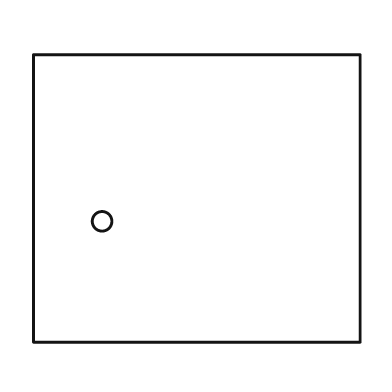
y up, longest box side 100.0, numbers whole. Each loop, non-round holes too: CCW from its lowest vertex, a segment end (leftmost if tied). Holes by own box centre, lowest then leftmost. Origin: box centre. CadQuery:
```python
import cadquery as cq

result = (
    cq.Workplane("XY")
    .moveTo(-50.0, -44.0)
    .lineTo(50.0, -44.0)
    .lineTo(50.0, 44.0)
    .lineTo(-50.0, 44.0)
    .close()
    .moveTo(-29.0, -7.0)
    .circle(3.0)
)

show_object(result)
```